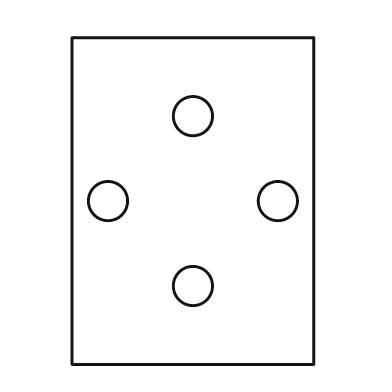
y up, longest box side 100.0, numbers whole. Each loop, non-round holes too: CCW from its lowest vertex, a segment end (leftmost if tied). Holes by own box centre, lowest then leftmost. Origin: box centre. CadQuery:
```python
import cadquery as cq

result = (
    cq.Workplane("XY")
    .moveTo(-37.0, -50.0)
    .lineTo(37.0, -50.0)
    .lineTo(37.0, 50.0)
    .lineTo(-37.0, 50.0)
    .close()
    .moveTo(0.0, -26.0)
    .circle(6.0)
    .moveTo(-26.0, 0.0)
    .circle(6.0)
    .moveTo(26.0, 0.0)
    .circle(6.0)
    .moveTo(0.0, 26.0)
    .circle(6.0)
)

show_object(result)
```